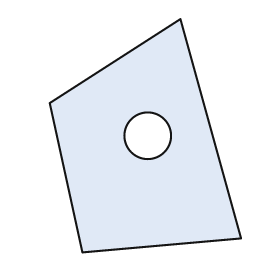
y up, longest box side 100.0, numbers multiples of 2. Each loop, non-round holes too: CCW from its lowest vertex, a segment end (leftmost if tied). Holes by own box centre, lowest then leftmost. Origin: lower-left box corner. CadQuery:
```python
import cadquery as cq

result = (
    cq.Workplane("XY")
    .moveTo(14.0, 0.0)
    .lineTo(82.0, 6.0)
    .lineTo(56.0, 100.0)
    .lineTo(0.0, 64.0)
    .close()
    .moveTo(42.0, 50.0)
    .circle(10.0)
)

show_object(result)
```